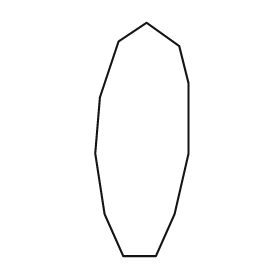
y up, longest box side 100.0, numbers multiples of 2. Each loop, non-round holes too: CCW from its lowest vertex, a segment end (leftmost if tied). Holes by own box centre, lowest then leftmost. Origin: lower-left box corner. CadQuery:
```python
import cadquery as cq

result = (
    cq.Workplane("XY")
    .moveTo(12.0, 0.0)
    .lineTo(26.0, 0.0)
    .lineTo(34.0, 18.0)
    .lineTo(40.0, 44.0)
    .lineTo(40.0, 74.0)
    .lineTo(36.0, 90.0)
    .lineTo(22.0, 100.0)
    .lineTo(10.0, 92.0)
    .lineTo(2.0, 68.0)
    .lineTo(0.0, 44.0)
    .lineTo(4.0, 18.0)
    .close()
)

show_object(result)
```